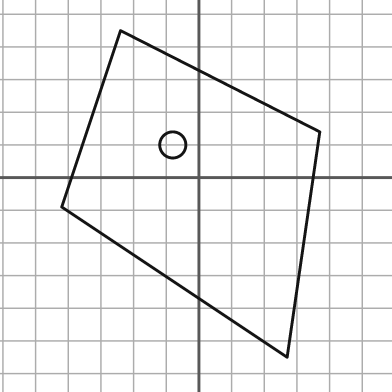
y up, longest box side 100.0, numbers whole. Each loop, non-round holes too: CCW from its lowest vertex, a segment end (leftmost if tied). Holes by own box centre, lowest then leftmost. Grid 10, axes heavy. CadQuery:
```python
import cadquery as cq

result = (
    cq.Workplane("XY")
    .moveTo(27.0, -55.0)
    .lineTo(37.0, 14.0)
    .lineTo(-24.0, 45.0)
    .lineTo(-42.0, -9.0)
    .close()
    .moveTo(-8.0, 10.0)
    .circle(4.0)
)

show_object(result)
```